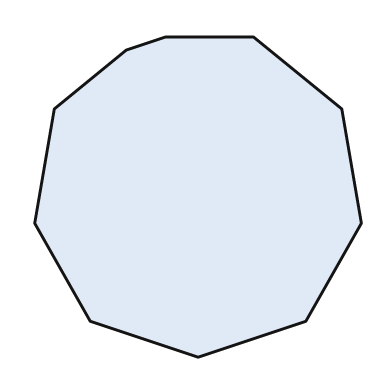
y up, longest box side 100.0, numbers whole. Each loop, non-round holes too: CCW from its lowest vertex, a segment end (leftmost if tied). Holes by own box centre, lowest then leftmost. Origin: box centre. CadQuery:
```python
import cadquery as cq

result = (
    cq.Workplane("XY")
    .moveTo(0.0, -49.0)
    .lineTo(33.0, -38.0)
    .lineTo(50.0, -8.0)
    .lineTo(44.0, 27.0)
    .lineTo(17.0, 49.0)
    .lineTo(-10.0, 49.0)
    .lineTo(-22.0, 45.0)
    .lineTo(-44.0, 27.0)
    .lineTo(-50.0, -8.0)
    .lineTo(-33.0, -38.0)
    .close()
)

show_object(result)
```